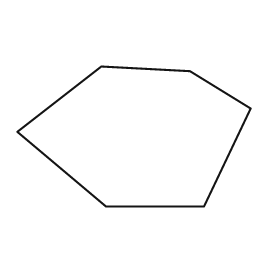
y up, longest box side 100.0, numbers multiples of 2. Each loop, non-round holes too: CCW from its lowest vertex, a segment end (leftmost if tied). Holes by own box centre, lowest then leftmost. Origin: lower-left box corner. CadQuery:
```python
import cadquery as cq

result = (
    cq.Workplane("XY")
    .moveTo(38.0, 0.0)
    .lineTo(80.0, 0.0)
    .lineTo(100.0, 42.0)
    .lineTo(74.0, 58.0)
    .lineTo(36.0, 60.0)
    .lineTo(0.0, 32.0)
    .close()
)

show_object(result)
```